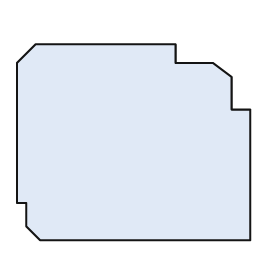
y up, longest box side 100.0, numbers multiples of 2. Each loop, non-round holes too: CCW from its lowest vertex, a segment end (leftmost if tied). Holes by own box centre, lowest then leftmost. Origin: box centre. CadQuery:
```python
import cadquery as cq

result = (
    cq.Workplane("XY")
    .moveTo(-40.0, -42.0)
    .lineTo(50.0, -42.0)
    .lineTo(50.0, 14.0)
    .lineTo(42.0, 14.0)
    .lineTo(42.0, 28.0)
    .lineTo(34.0, 34.0)
    .lineTo(18.0, 34.0)
    .lineTo(18.0, 42.0)
    .lineTo(-42.0, 42.0)
    .lineTo(-50.0, 34.0)
    .lineTo(-50.0, -26.0)
    .lineTo(-46.0, -26.0)
    .lineTo(-46.0, -36.0)
    .close()
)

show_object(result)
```